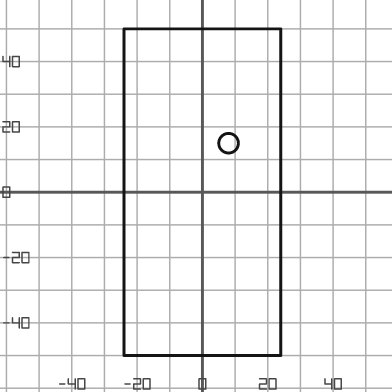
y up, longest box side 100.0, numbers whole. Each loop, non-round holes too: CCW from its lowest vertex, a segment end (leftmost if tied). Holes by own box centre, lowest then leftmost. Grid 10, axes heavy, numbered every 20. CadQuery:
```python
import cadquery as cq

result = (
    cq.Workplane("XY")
    .moveTo(-24.0, -50.0)
    .lineTo(24.0, -50.0)
    .lineTo(24.0, 50.0)
    .lineTo(-24.0, 50.0)
    .close()
    .moveTo(8.0, 15.0)
    .circle(3.0)
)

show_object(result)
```